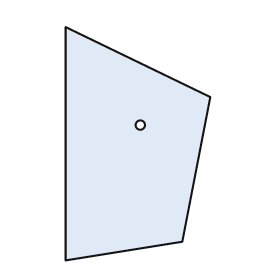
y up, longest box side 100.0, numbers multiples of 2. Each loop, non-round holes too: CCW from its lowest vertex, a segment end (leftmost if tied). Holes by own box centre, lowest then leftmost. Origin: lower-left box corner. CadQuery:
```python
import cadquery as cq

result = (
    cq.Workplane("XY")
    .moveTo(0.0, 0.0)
    .lineTo(50.0, 8.0)
    .lineTo(62.0, 70.0)
    .lineTo(0.0, 100.0)
    .close()
    .moveTo(32.0, 58.0)
    .circle(2.0)
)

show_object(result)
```